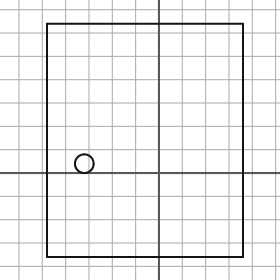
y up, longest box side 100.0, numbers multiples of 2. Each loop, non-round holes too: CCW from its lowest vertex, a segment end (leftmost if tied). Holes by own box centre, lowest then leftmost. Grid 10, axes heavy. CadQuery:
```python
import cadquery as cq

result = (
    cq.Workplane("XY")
    .moveTo(-48.0, -36.0)
    .lineTo(36.0, -36.0)
    .lineTo(36.0, 64.0)
    .lineTo(-48.0, 64.0)
    .close()
    .moveTo(-32.0, 4.0)
    .circle(4.0)
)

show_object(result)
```